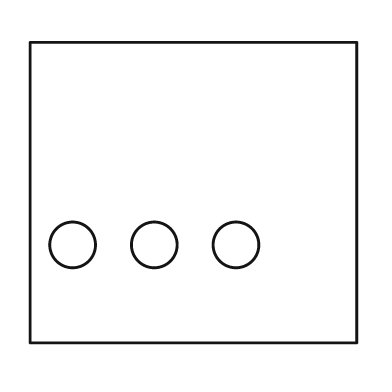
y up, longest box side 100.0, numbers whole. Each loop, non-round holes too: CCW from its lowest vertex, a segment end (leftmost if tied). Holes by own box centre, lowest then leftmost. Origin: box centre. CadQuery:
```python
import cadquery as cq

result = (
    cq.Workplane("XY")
    .moveTo(-50.0, -46.0)
    .lineTo(50.0, -46.0)
    .lineTo(50.0, 46.0)
    .lineTo(-50.0, 46.0)
    .close()
    .moveTo(-37.0, -16.0)
    .circle(7.0)
    .moveTo(-12.0, -16.0)
    .circle(7.0)
    .moveTo(13.0, -16.0)
    .circle(7.0)
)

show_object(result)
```